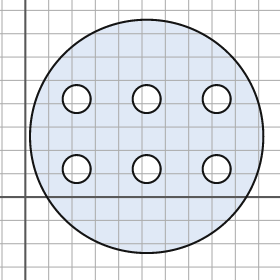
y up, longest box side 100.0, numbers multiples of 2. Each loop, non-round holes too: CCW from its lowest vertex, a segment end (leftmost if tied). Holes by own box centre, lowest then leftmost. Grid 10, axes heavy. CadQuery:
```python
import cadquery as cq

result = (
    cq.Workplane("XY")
    .moveTo(52.0, 26.0)
    .circle(50.0)
    .moveTo(22.0, 12.0)
    .circle(6.0)
    .moveTo(52.0, 12.0)
    .circle(6.0)
    .moveTo(82.0, 12.0)
    .circle(6.0)
    .moveTo(22.0, 42.0)
    .circle(6.0)
    .moveTo(52.0, 42.0)
    .circle(6.0)
    .moveTo(82.0, 42.0)
    .circle(6.0)
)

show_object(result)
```